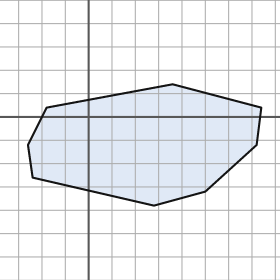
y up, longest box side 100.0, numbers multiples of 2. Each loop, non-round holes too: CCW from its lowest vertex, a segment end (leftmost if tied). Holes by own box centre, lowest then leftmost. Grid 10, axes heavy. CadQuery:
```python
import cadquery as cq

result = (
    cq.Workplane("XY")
    .moveTo(28.0, -38.0)
    .lineTo(50.0, -32.0)
    .lineTo(72.0, -12.0)
    .lineTo(74.0, 4.0)
    .lineTo(36.0, 14.0)
    .lineTo(-18.0, 4.0)
    .lineTo(-26.0, -12.0)
    .lineTo(-24.0, -26.0)
    .close()
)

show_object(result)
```